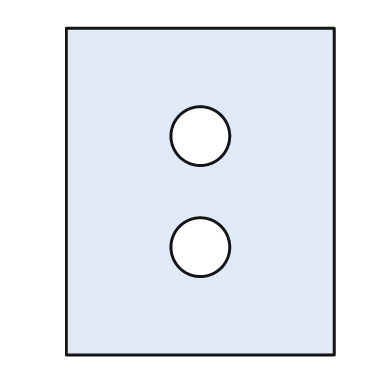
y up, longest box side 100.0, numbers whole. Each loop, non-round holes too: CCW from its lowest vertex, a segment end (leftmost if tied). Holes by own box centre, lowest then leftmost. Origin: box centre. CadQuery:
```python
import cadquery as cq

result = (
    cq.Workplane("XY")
    .moveTo(-41.0, -50.0)
    .lineTo(41.0, -50.0)
    .lineTo(41.0, 50.0)
    .lineTo(-41.0, 50.0)
    .close()
    .moveTo(0.0, -17.0)
    .circle(9.0)
    .moveTo(0.0, 17.0)
    .circle(9.0)
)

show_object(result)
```